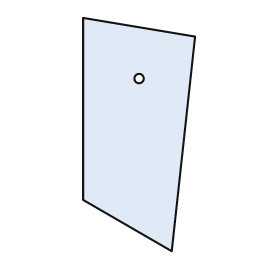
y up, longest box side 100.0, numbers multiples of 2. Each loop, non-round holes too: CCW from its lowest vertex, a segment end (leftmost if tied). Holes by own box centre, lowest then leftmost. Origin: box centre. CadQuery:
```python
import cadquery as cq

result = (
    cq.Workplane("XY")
    .moveTo(14.0, -50.0)
    .lineTo(24.0, 42.0)
    .lineTo(-24.0, 50.0)
    .lineTo(-24.0, -28.0)
    .close()
    .moveTo(0.0, 24.0)
    .circle(2.0)
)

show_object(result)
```